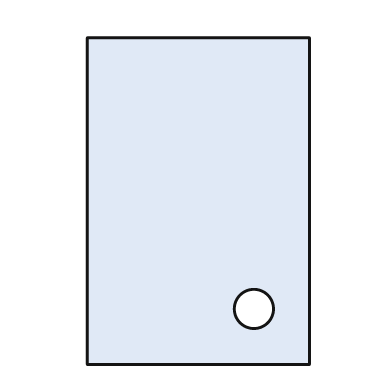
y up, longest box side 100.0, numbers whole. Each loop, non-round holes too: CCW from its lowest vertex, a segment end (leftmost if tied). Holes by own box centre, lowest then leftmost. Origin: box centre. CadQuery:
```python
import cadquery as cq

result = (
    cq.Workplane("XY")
    .moveTo(-34.0, -50.0)
    .lineTo(34.0, -50.0)
    .lineTo(34.0, 50.0)
    .lineTo(-34.0, 50.0)
    .close()
    .moveTo(17.0, -33.0)
    .circle(6.0)
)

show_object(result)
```